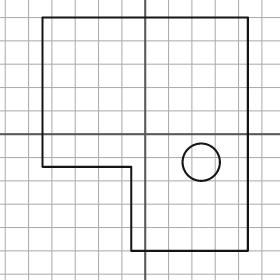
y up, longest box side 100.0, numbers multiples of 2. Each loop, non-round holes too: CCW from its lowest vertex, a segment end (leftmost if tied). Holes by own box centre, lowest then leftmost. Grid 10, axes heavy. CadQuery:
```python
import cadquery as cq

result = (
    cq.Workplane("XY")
    .moveTo(-6.0, -50.0)
    .lineTo(44.0, -50.0)
    .lineTo(44.0, 50.0)
    .lineTo(-44.0, 50.0)
    .lineTo(-44.0, -14.0)
    .lineTo(-6.0, -14.0)
    .close()
    .moveTo(24.0, -12.0)
    .circle(8.0)
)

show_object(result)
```